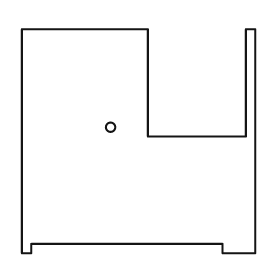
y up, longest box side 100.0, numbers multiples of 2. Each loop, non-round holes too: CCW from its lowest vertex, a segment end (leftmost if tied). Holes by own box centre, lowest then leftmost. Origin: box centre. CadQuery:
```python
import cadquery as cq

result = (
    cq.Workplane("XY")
    .moveTo(-50.0, -48.0)
    .lineTo(-46.0, -48.0)
    .lineTo(-46.0, -44.0)
    .lineTo(36.0, -44.0)
    .lineTo(36.0, -48.0)
    .lineTo(50.0, -48.0)
    .lineTo(50.0, 48.0)
    .lineTo(46.0, 48.0)
    .lineTo(46.0, 2.0)
    .lineTo(4.0, 2.0)
    .lineTo(4.0, 48.0)
    .lineTo(-50.0, 48.0)
    .close()
    .moveTo(-12.0, 6.0)
    .circle(2.0)
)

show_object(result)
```